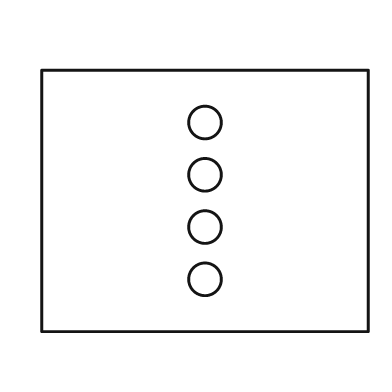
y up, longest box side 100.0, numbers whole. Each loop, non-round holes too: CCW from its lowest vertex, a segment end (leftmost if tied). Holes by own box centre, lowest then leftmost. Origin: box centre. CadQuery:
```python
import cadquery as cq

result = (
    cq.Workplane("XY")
    .moveTo(-50.0, -40.0)
    .lineTo(50.0, -40.0)
    .lineTo(50.0, 40.0)
    .lineTo(-50.0, 40.0)
    .close()
    .moveTo(0.0, -24.0)
    .circle(5.0)
    .moveTo(0.0, -8.0)
    .circle(5.0)
    .moveTo(0.0, 8.0)
    .circle(5.0)
    .moveTo(0.0, 24.0)
    .circle(5.0)
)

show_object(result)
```